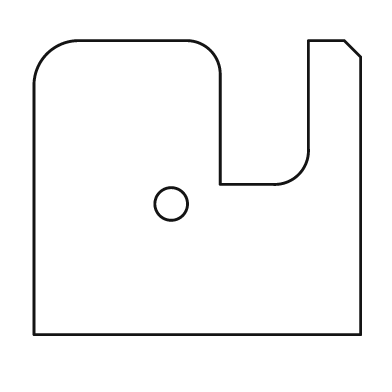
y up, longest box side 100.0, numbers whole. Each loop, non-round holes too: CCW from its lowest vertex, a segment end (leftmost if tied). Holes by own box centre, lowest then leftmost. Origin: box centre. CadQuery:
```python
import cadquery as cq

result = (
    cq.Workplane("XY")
    .moveTo(-50.0, -45.0)
    .lineTo(50.0, -45.0)
    .lineTo(50.0, 40.0)
    .lineTo(45.0, 45.0)
    .lineTo(34.0, 45.0)
    .lineTo(34.0, 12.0)
    .threePointArc((31.0, 4.0), (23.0, 1.0))
    .lineTo(7.0, 1.0)
    .lineTo(7.0, 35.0)
    .threePointArc((4.0, 42.0), (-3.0, 45.0))
    .lineTo(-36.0, 45.0)
    .threePointArc((-46.0, 41.0), (-50.0, 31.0))
    .close()
    .moveTo(-8.0, -5.0)
    .circle(5.0)
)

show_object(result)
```